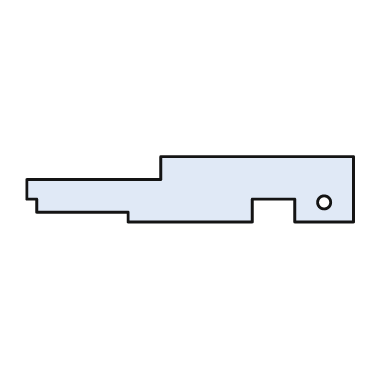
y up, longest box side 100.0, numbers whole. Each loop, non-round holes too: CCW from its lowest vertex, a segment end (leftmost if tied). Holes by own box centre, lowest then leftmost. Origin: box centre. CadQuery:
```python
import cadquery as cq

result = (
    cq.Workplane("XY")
    .moveTo(-19.0, -10.0)
    .lineTo(19.0, -10.0)
    .lineTo(19.0, -3.0)
    .lineTo(32.0, -3.0)
    .lineTo(32.0, -10.0)
    .lineTo(50.0, -10.0)
    .lineTo(50.0, 10.0)
    .lineTo(-9.0, 10.0)
    .lineTo(-9.0, 3.0)
    .lineTo(-50.0, 3.0)
    .lineTo(-50.0, -3.0)
    .lineTo(-47.0, -3.0)
    .lineTo(-47.0, -7.0)
    .lineTo(-19.0, -7.0)
    .close()
    .moveTo(41.0, -4.0)
    .circle(2.0)
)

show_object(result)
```